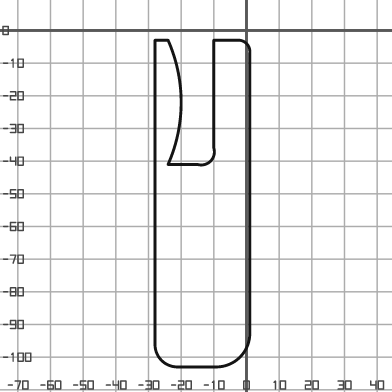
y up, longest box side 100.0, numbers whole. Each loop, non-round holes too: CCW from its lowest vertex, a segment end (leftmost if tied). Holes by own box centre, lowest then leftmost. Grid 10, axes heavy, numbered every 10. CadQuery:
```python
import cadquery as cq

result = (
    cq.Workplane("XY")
    .moveTo(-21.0, -103.0)
    .lineTo(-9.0, -103.0)
    .threePointArc((-2.0, -100.0), (1.0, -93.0))
    .lineTo(1.0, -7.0)
    .threePointArc((0.0, -4.0), (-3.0, -3.0))
    .lineTo(-10.0, -3.0)
    .lineTo(-10.0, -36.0)
    .threePointArc((-11.0, -40.0), (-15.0, -41.0))
    .lineTo(-24.0, -41.0)
    .threePointArc((-20.0, -22.0), (-24.0, -3.0))
    .lineTo(-28.0, -3.0)
    .lineTo(-28.0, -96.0)
    .threePointArc((-26.0, -101.0), (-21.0, -103.0))
    .close()
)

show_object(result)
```